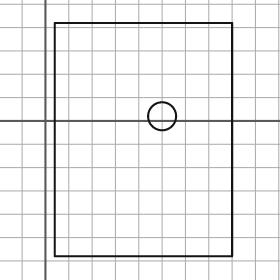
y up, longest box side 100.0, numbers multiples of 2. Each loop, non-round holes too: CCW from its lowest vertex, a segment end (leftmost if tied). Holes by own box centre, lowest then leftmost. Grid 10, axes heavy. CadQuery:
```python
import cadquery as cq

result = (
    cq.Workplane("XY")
    .moveTo(4.0, -58.0)
    .lineTo(80.0, -58.0)
    .lineTo(80.0, 42.0)
    .lineTo(4.0, 42.0)
    .close()
    .moveTo(50.0, 2.0)
    .circle(6.0)
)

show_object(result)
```